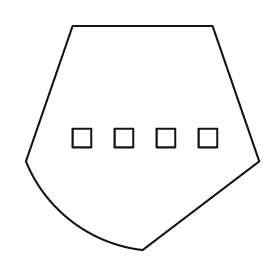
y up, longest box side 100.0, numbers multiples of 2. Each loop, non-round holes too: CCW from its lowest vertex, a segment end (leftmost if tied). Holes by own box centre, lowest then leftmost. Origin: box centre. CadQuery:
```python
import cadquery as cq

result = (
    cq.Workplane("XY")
    .moveTo(0.0, -48.0)
    .lineTo(50.0, -10.0)
    .lineTo(30.0, 48.0)
    .lineTo(-30.0, 48.0)
    .lineTo(-50.0, -10.0)
    .threePointArc((-30.0, -36.0), (0.0, -48.0))
    .close()
    .moveTo(-30.0, -4.0)
    .lineTo(-22.0, -4.0)
    .lineTo(-22.0, 4.0)
    .lineTo(-30.0, 4.0)
    .close()
    .moveTo(-12.0, -4.0)
    .lineTo(-4.0, -4.0)
    .lineTo(-4.0, 4.0)
    .lineTo(-12.0, 4.0)
    .close()
    .moveTo(6.0, -4.0)
    .lineTo(14.0, -4.0)
    .lineTo(14.0, 4.0)
    .lineTo(6.0, 4.0)
    .close()
    .moveTo(24.0, -4.0)
    .lineTo(32.0, -4.0)
    .lineTo(32.0, 4.0)
    .lineTo(24.0, 4.0)
    .close()
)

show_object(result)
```